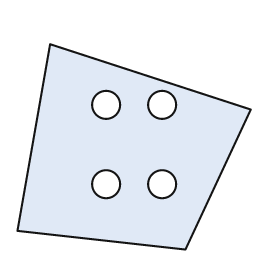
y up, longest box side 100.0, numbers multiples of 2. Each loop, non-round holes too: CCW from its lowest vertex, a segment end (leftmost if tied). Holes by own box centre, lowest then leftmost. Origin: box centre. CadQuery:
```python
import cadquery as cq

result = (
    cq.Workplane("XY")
    .moveTo(22.0, -44.0)
    .lineTo(50.0, 16.0)
    .lineTo(-36.0, 44.0)
    .lineTo(-50.0, -36.0)
    .close()
    .moveTo(-12.0, -16.0)
    .circle(6.0)
    .moveTo(12.0, -16.0)
    .circle(6.0)
    .moveTo(-12.0, 18.0)
    .circle(6.0)
    .moveTo(12.0, 18.0)
    .circle(6.0)
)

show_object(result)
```